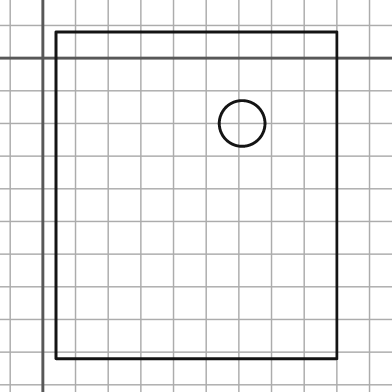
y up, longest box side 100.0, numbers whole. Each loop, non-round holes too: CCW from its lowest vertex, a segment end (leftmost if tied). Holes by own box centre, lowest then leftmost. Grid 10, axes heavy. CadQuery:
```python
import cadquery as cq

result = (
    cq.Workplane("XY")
    .moveTo(4.0, -92.0)
    .lineTo(90.0, -92.0)
    .lineTo(90.0, 8.0)
    .lineTo(4.0, 8.0)
    .close()
    .moveTo(61.0, -20.0)
    .circle(7.0)
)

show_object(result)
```